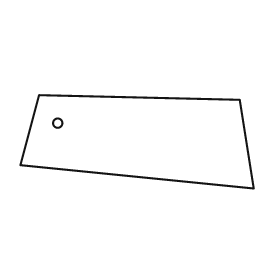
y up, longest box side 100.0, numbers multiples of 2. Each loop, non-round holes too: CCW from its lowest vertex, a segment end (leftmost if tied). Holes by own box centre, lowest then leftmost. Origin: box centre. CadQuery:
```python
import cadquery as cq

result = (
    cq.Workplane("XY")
    .moveTo(50.0, -20.0)
    .lineTo(44.0, 18.0)
    .lineTo(-42.0, 20.0)
    .lineTo(-50.0, -10.0)
    .close()
    .moveTo(-34.0, 8.0)
    .circle(2.0)
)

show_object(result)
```